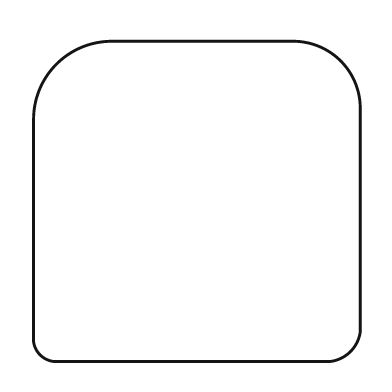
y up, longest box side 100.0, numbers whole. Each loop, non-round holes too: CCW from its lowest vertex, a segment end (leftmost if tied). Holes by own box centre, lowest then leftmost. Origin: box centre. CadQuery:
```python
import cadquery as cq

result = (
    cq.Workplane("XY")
    .moveTo(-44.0, -49.0)
    .lineTo(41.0, -49.0)
    .threePointArc((47.0, -46.0), (50.0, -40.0))
    .lineTo(50.0, 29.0)
    .threePointArc((44.0, 43.0), (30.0, 49.0))
    .lineTo(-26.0, 49.0)
    .threePointArc((-43.0, 42.0), (-50.0, 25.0))
    .lineTo(-50.0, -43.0)
    .threePointArc((-48.0, -47.0), (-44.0, -49.0))
    .close()
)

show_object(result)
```